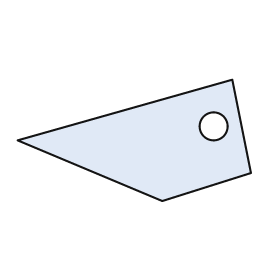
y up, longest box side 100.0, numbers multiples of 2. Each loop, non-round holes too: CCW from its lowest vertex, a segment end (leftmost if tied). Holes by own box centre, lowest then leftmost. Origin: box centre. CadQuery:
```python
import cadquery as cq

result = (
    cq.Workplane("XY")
    .moveTo(12.0, -26.0)
    .lineTo(50.0, -14.0)
    .lineTo(42.0, 26.0)
    .lineTo(-50.0, 0.0)
    .close()
    .moveTo(34.0, 6.0)
    .circle(6.0)
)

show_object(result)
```